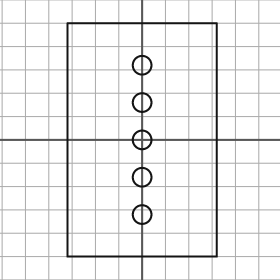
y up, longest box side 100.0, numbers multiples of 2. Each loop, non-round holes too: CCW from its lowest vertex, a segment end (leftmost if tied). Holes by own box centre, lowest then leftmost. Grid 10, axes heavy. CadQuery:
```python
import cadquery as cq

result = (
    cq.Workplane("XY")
    .moveTo(-32.0, -50.0)
    .lineTo(32.0, -50.0)
    .lineTo(32.0, 50.0)
    .lineTo(-32.0, 50.0)
    .close()
    .moveTo(0.0, -32.0)
    .circle(4.0)
    .moveTo(0.0, -16.0)
    .circle(4.0)
    .moveTo(0.0, 0.0)
    .circle(4.0)
    .moveTo(0.0, 16.0)
    .circle(4.0)
    .moveTo(0.0, 32.0)
    .circle(4.0)
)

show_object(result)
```